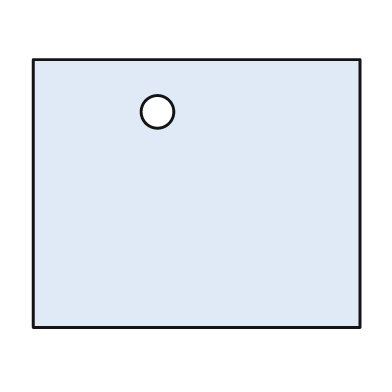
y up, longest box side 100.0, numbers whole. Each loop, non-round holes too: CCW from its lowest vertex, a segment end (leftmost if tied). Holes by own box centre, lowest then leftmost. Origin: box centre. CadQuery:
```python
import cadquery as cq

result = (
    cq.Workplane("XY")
    .moveTo(-50.0, -41.0)
    .lineTo(50.0, -41.0)
    .lineTo(50.0, 41.0)
    .lineTo(-50.0, 41.0)
    .close()
    .moveTo(-12.0, 25.0)
    .circle(5.0)
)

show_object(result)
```